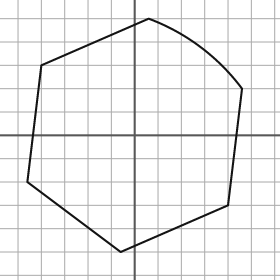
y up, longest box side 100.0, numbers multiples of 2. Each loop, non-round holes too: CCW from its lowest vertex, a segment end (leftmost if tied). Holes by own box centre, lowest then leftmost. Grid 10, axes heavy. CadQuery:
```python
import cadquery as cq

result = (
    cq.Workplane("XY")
    .moveTo(-6.0, -50.0)
    .lineTo(40.0, -30.0)
    .lineTo(46.0, 20.0)
    .threePointArc((28.0, 38.0), (6.0, 50.0))
    .lineTo(-40.0, 30.0)
    .lineTo(-46.0, -20.0)
    .close()
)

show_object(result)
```